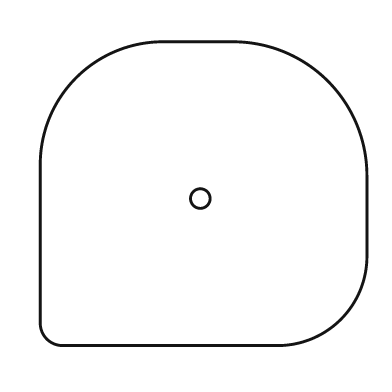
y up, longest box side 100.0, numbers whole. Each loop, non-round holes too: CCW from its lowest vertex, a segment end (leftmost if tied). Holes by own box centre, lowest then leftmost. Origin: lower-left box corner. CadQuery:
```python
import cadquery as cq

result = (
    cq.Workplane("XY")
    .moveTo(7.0, 0.0)
    .lineTo(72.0, 0.0)
    .threePointArc((92.0, 8.0), (100.0, 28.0))
    .lineTo(100.0, 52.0)
    .threePointArc((88.0, 81.0), (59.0, 93.0))
    .lineTo(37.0, 93.0)
    .threePointArc((11.0, 82.0), (0.0, 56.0))
    .lineTo(0.0, 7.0)
    .threePointArc((2.0, 2.0), (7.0, 0.0))
    .close()
    .moveTo(49.0, 45.0)
    .circle(3.0)
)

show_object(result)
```